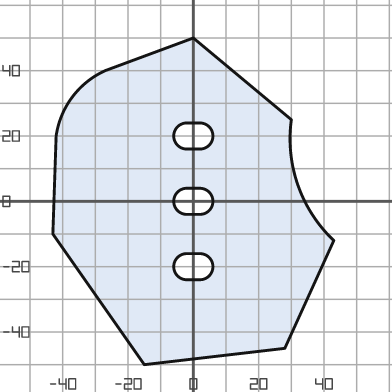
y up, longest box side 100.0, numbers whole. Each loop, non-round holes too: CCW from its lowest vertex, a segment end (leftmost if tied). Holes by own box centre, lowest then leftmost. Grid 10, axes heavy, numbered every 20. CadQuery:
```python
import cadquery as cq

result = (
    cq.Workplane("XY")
    .moveTo(-15.0, -50.0)
    .lineTo(28.0, -45.0)
    .lineTo(43.0, -12.0)
    .threePointArc((32.0, 5.0), (30.0, 25.0))
    .lineTo(0.0, 50.0)
    .lineTo(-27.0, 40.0)
    .threePointArc((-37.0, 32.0), (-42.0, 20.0))
    .lineTo(-43.0, -10.0)
    .close()
    .moveTo(-2.0, -24.0)
    .lineTo(2.0, -24.0)
    .threePointArc((6.0, -20.0), (2.0, -16.0))
    .lineTo(-2.0, -16.0)
    .threePointArc((-6.0, -20.0), (-2.0, -24.0))
    .close()
    .moveTo(-2.0, -4.0)
    .lineTo(2.0, -4.0)
    .threePointArc((6.0, 0.0), (2.0, 4.0))
    .lineTo(-2.0, 4.0)
    .threePointArc((-6.0, 0.0), (-2.0, -4.0))
    .close()
    .moveTo(-2.0, 16.0)
    .lineTo(2.0, 16.0)
    .threePointArc((6.0, 20.0), (2.0, 24.0))
    .lineTo(-2.0, 24.0)
    .threePointArc((-6.0, 20.0), (-2.0, 16.0))
    .close()
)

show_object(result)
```